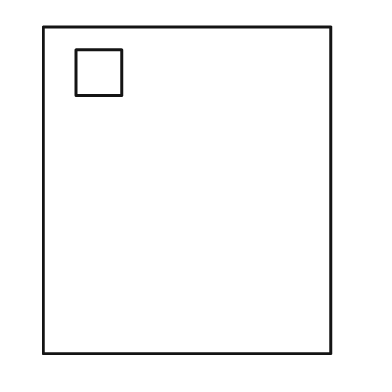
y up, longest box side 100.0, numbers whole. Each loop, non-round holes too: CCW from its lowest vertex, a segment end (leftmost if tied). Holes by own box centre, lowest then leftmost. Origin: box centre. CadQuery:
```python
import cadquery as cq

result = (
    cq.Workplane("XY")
    .moveTo(-44.0, -50.0)
    .lineTo(44.0, -50.0)
    .lineTo(44.0, 50.0)
    .lineTo(-44.0, 50.0)
    .close()
    .moveTo(-34.0, 29.0)
    .lineTo(-20.0, 29.0)
    .lineTo(-20.0, 43.0)
    .lineTo(-34.0, 43.0)
    .close()
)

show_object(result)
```